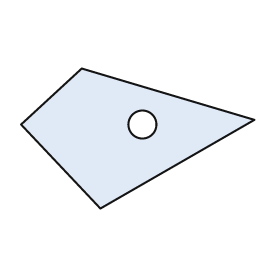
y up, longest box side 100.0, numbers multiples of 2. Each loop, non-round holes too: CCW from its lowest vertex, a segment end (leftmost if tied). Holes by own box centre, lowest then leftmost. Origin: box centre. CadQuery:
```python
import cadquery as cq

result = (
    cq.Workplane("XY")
    .moveTo(-16.0, -30.0)
    .lineTo(50.0, 8.0)
    .lineTo(-24.0, 30.0)
    .lineTo(-50.0, 6.0)
    .close()
    .moveTo(2.0, 6.0)
    .circle(6.0)
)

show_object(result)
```